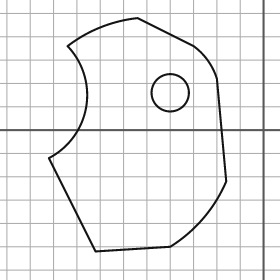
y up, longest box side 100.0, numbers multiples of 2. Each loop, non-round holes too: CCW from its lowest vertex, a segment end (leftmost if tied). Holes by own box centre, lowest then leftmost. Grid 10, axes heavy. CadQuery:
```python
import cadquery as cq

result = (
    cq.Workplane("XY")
    .moveTo(-72.0, -52.0)
    .lineTo(-40.0, -50.0)
    .threePointArc((-26.0, -38.0), (-16.0, -22.0))
    .lineTo(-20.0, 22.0)
    .threePointArc((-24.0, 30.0), (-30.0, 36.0))
    .lineTo(-54.0, 48.0)
    .threePointArc((-70.0, 44.0), (-84.0, 36.0))
    .threePointArc((-76.0, 10.0), (-92.0, -12.0))
    .close()
    .moveTo(-40.0, 16.0)
    .circle(8.0)
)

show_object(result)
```